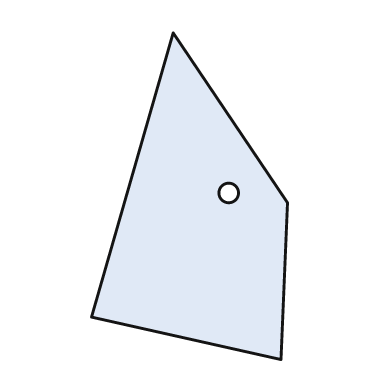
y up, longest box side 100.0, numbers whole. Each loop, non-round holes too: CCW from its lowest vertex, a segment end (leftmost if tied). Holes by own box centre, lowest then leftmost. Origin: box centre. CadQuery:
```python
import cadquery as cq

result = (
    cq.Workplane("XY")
    .moveTo(28.0, -50.0)
    .lineTo(30.0, -2.0)
    .lineTo(-5.0, 50.0)
    .lineTo(-30.0, -37.0)
    .close()
    .moveTo(12.0, 1.0)
    .circle(3.0)
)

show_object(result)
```